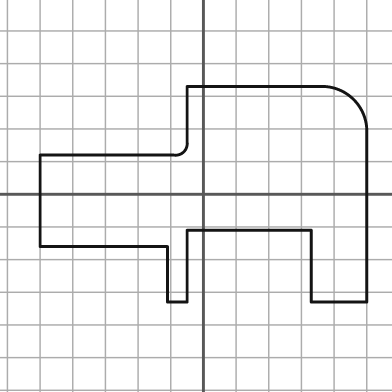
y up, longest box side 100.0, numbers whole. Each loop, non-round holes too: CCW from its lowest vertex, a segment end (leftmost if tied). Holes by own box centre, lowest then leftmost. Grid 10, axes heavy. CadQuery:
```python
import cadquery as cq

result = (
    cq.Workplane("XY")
    .moveTo(-11.0, -33.0)
    .lineTo(-5.0, -33.0)
    .lineTo(-5.0, -11.0)
    .lineTo(33.0, -11.0)
    .lineTo(33.0, -33.0)
    .lineTo(50.0, -33.0)
    .lineTo(50.0, 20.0)
    .threePointArc((46.0, 29.0), (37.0, 33.0))
    .lineTo(-5.0, 33.0)
    .lineTo(-5.0, 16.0)
    .threePointArc((-6.0, 13.0), (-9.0, 12.0))
    .lineTo(-50.0, 12.0)
    .lineTo(-50.0, -16.0)
    .lineTo(-11.0, -16.0)
    .close()
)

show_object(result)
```